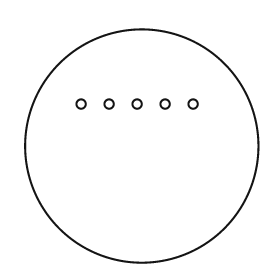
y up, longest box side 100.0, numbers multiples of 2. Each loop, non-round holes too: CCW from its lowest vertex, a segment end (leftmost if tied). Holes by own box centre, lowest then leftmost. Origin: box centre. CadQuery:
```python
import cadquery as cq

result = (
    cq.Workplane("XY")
    .moveTo(0.0, 0.0)
    .circle(50.0)
    .moveTo(-26.0, 18.0)
    .circle(2.0)
    .moveTo(-14.0, 18.0)
    .circle(2.0)
    .moveTo(-2.0, 18.0)
    .circle(2.0)
    .moveTo(10.0, 18.0)
    .circle(2.0)
    .moveTo(22.0, 18.0)
    .circle(2.0)
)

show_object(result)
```